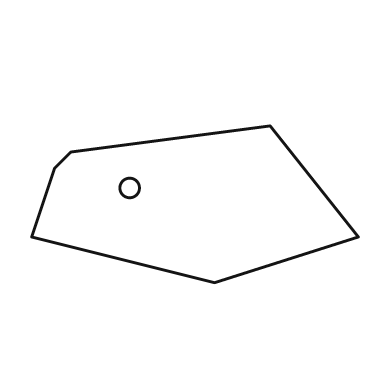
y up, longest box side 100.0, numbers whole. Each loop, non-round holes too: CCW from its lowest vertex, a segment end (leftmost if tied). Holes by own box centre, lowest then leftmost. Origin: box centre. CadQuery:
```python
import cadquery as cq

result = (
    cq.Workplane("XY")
    .moveTo(6.0, -24.0)
    .lineTo(50.0, -10.0)
    .lineTo(23.0, 24.0)
    .lineTo(-38.0, 16.0)
    .lineTo(-43.0, 11.0)
    .lineTo(-50.0, -10.0)
    .close()
    .moveTo(-20.0, 5.0)
    .circle(3.0)
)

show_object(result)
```